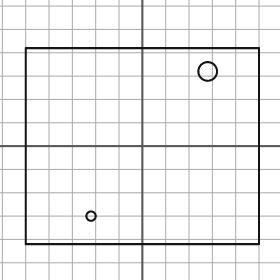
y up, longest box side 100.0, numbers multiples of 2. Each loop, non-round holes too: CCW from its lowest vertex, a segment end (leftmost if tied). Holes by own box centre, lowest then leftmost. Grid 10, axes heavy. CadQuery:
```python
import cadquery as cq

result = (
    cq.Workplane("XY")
    .moveTo(-50.0, -42.0)
    .lineTo(50.0, -42.0)
    .lineTo(50.0, 42.0)
    .lineTo(-50.0, 42.0)
    .close()
    .moveTo(-22.0, -30.0)
    .circle(2.0)
    .moveTo(28.0, 32.0)
    .circle(4.0)
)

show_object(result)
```